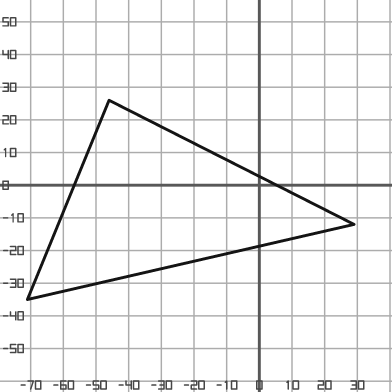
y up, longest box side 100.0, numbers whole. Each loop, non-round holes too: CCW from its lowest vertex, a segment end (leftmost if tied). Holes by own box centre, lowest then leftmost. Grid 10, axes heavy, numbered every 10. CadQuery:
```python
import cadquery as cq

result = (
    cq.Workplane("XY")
    .moveTo(-71.0, -35.0)
    .lineTo(29.0, -12.0)
    .lineTo(-46.0, 26.0)
    .close()
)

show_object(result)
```